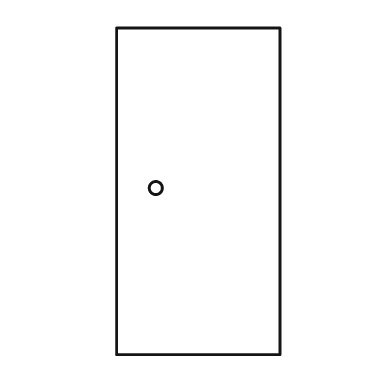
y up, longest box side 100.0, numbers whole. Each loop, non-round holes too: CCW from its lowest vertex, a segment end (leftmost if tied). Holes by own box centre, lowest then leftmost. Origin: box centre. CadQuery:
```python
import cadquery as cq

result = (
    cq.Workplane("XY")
    .moveTo(-25.0, -50.0)
    .lineTo(25.0, -50.0)
    .lineTo(25.0, 50.0)
    .lineTo(-25.0, 50.0)
    .close()
    .moveTo(-13.0, 1.0)
    .circle(2.0)
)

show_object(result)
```